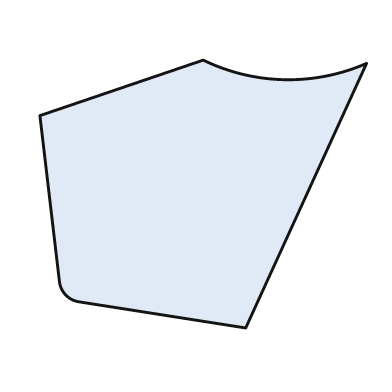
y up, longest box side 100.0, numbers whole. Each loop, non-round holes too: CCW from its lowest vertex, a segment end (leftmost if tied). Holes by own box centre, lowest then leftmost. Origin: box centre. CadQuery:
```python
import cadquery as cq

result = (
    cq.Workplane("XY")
    .moveTo(13.0, -41.0)
    .lineTo(50.0, 40.0)
    .threePointArc((25.0, 35.0), (0.0, 41.0))
    .lineTo(-50.0, 24.0)
    .lineTo(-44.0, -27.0)
    .threePointArc((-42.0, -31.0), (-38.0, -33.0))
    .close()
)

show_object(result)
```